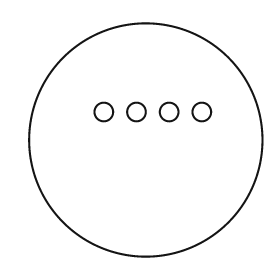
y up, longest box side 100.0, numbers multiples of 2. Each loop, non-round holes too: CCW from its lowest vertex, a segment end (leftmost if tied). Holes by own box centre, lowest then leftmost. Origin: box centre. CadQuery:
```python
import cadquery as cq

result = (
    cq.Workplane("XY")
    .moveTo(0.0, 0.0)
    .circle(50.0)
    .moveTo(-18.0, 12.0)
    .circle(4.0)
    .moveTo(-4.0, 12.0)
    .circle(4.0)
    .moveTo(10.0, 12.0)
    .circle(4.0)
    .moveTo(24.0, 12.0)
    .circle(4.0)
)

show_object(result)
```